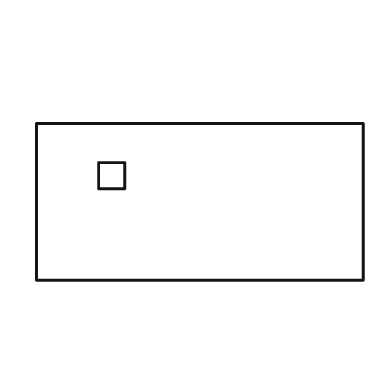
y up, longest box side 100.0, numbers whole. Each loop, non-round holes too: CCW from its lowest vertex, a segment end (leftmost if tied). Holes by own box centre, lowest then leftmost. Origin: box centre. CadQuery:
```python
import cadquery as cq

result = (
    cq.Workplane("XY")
    .moveTo(-50.0, -24.0)
    .lineTo(50.0, -24.0)
    .lineTo(50.0, 24.0)
    .lineTo(-50.0, 24.0)
    .close()
    .moveTo(-31.0, 4.0)
    .lineTo(-23.0, 4.0)
    .lineTo(-23.0, 12.0)
    .lineTo(-31.0, 12.0)
    .close()
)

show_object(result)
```